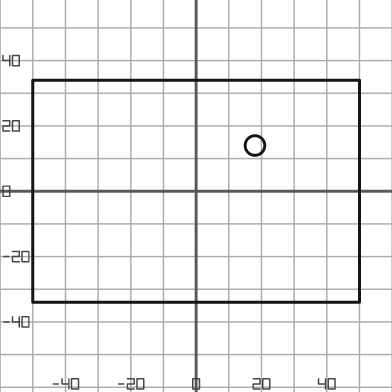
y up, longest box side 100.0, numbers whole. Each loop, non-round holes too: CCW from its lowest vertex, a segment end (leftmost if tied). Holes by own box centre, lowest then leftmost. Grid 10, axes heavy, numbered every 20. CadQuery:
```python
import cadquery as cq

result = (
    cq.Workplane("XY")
    .moveTo(-50.0, -34.0)
    .lineTo(50.0, -34.0)
    .lineTo(50.0, 34.0)
    .lineTo(-50.0, 34.0)
    .close()
    .moveTo(18.0, 14.0)
    .circle(3.0)
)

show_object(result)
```